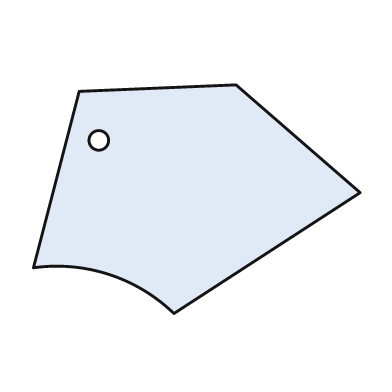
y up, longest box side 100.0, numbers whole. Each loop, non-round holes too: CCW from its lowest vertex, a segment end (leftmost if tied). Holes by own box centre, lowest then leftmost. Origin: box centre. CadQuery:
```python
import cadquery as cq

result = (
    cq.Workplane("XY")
    .moveTo(-7.0, -35.0)
    .lineTo(50.0, 2.0)
    .lineTo(12.0, 35.0)
    .lineTo(-36.0, 33.0)
    .lineTo(-50.0, -21.0)
    .threePointArc((-27.0, -23.0), (-7.0, -35.0))
    .close()
    .moveTo(-30.0, 18.0)
    .circle(3.0)
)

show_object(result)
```